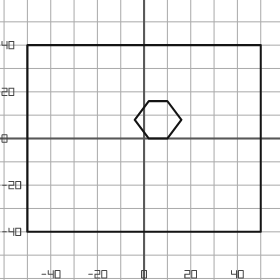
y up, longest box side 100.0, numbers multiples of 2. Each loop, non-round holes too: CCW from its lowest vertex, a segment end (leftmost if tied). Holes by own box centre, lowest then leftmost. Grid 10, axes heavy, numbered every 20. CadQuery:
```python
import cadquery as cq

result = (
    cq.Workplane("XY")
    .moveTo(-50.0, -40.0)
    .lineTo(50.0, -40.0)
    .lineTo(50.0, 40.0)
    .lineTo(-50.0, 40.0)
    .close()
    .moveTo(2.0, 0.0)
    .lineTo(10.0, 0.0)
    .lineTo(16.0, 8.0)
    .lineTo(10.0, 16.0)
    .lineTo(2.0, 16.0)
    .lineTo(-4.0, 8.0)
    .close()
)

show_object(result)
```